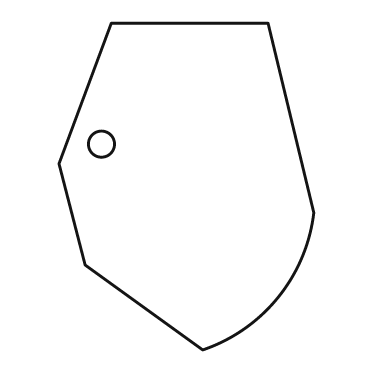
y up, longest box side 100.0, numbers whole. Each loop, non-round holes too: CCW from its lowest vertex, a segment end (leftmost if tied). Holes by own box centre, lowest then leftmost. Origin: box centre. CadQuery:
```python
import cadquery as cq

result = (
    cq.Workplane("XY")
    .moveTo(5.0, -50.0)
    .threePointArc((28.0, -34.0), (39.0, -8.0))
    .lineTo(25.0, 50.0)
    .lineTo(-23.0, 50.0)
    .lineTo(-39.0, 7.0)
    .lineTo(-31.0, -24.0)
    .close()
    .moveTo(-26.0, 13.0)
    .circle(4.0)
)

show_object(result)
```